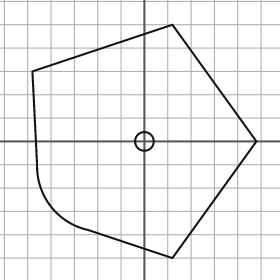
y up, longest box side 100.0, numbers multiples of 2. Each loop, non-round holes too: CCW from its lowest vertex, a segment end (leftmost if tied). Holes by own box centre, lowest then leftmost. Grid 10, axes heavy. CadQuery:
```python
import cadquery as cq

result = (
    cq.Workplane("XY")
    .moveTo(12.0, -50.0)
    .lineTo(48.0, 0.0)
    .lineTo(12.0, 50.0)
    .lineTo(-48.0, 30.0)
    .lineTo(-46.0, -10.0)
    .threePointArc((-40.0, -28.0), (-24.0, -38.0))
    .close()
    .moveTo(0.0, 0.0)
    .circle(4.0)
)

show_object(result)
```